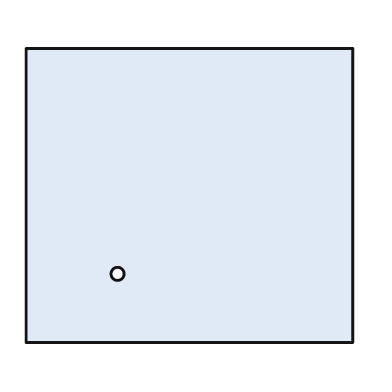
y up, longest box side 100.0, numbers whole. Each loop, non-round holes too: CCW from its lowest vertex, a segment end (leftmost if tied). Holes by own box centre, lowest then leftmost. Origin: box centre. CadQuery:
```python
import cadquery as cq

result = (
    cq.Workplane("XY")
    .moveTo(-50.0, -45.0)
    .lineTo(50.0, -45.0)
    .lineTo(50.0, 45.0)
    .lineTo(-50.0, 45.0)
    .close()
    .moveTo(-22.0, -24.0)
    .circle(2.0)
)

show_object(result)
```